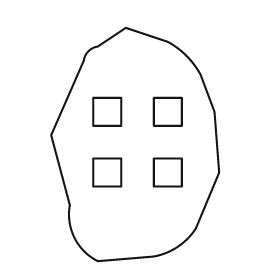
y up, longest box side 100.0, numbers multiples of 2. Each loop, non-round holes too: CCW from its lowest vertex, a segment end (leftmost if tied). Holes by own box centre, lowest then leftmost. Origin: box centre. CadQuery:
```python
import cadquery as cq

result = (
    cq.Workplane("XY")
    .moveTo(-16.0, -50.0)
    .lineTo(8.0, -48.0)
    .threePointArc((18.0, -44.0), (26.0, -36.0))
    .lineTo(36.0, -12.0)
    .lineTo(34.0, 14.0)
    .lineTo(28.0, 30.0)
    .threePointArc((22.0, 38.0), (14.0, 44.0))
    .lineTo(-4.0, 50.0)
    .lineTo(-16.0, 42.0)
    .threePointArc((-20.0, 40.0), (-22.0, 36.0))
    .lineTo(-36.0, 4.0)
    .lineTo(-28.0, -26.0)
    .threePointArc((-26.0, -40.0), (-16.0, -50.0))
    .close()
    .moveTo(-18.0, -18.0)
    .lineTo(-6.0, -18.0)
    .lineTo(-6.0, -6.0)
    .lineTo(-18.0, -6.0)
    .close()
    .moveTo(8.0, -18.0)
    .lineTo(20.0, -18.0)
    .lineTo(20.0, -6.0)
    .lineTo(8.0, -6.0)
    .close()
    .moveTo(-18.0, 8.0)
    .lineTo(-6.0, 8.0)
    .lineTo(-6.0, 20.0)
    .lineTo(-18.0, 20.0)
    .close()
    .moveTo(8.0, 8.0)
    .lineTo(20.0, 8.0)
    .lineTo(20.0, 20.0)
    .lineTo(8.0, 20.0)
    .close()
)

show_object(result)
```